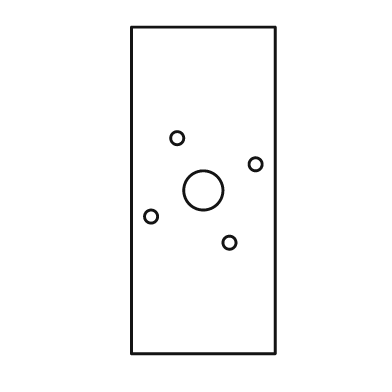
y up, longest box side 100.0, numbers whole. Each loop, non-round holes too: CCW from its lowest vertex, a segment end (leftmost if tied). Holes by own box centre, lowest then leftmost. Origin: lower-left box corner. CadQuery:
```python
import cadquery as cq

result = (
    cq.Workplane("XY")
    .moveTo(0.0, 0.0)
    .lineTo(44.0, 0.0)
    .lineTo(44.0, 100.0)
    .lineTo(0.0, 100.0)
    .close()
    .moveTo(30.0, 34.0)
    .circle(2.0)
    .moveTo(6.0, 42.0)
    .circle(2.0)
    .moveTo(22.0, 50.0)
    .circle(6.0)
    .moveTo(38.0, 58.0)
    .circle(2.0)
    .moveTo(14.0, 66.0)
    .circle(2.0)
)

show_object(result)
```